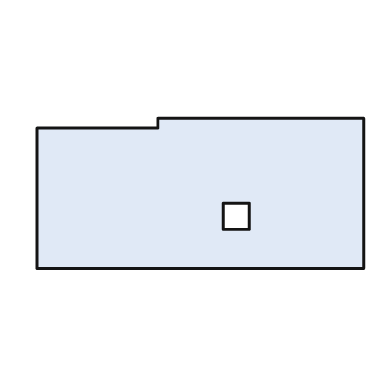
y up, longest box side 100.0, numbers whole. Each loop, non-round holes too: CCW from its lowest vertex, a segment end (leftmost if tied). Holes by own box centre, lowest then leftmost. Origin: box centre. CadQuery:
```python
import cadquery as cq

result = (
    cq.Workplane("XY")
    .moveTo(-50.0, -23.0)
    .lineTo(50.0, -23.0)
    .lineTo(50.0, 23.0)
    .lineTo(-13.0, 23.0)
    .lineTo(-13.0, 20.0)
    .lineTo(-50.0, 20.0)
    .close()
    .moveTo(7.0, -11.0)
    .lineTo(15.0, -11.0)
    .lineTo(15.0, -3.0)
    .lineTo(7.0, -3.0)
    .close()
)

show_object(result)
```